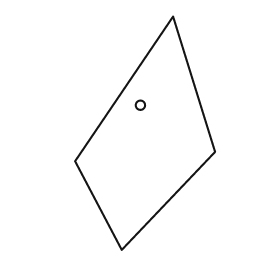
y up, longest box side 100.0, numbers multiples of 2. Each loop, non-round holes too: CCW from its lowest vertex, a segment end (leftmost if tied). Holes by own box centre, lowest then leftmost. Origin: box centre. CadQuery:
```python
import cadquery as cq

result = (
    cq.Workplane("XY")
    .moveTo(-10.0, -50.0)
    .lineTo(30.0, -8.0)
    .lineTo(12.0, 50.0)
    .lineTo(-30.0, -12.0)
    .close()
    .moveTo(-2.0, 12.0)
    .circle(2.0)
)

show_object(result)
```